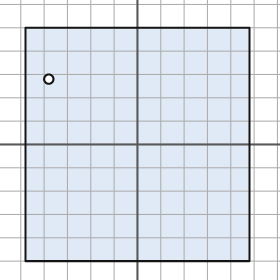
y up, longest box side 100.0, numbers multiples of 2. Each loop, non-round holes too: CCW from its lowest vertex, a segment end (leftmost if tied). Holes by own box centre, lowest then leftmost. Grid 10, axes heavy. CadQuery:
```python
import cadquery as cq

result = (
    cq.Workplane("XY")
    .moveTo(-48.0, -50.0)
    .lineTo(48.0, -50.0)
    .lineTo(48.0, 50.0)
    .lineTo(-48.0, 50.0)
    .close()
    .moveTo(-38.0, 28.0)
    .circle(2.0)
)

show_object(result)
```